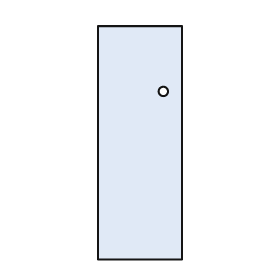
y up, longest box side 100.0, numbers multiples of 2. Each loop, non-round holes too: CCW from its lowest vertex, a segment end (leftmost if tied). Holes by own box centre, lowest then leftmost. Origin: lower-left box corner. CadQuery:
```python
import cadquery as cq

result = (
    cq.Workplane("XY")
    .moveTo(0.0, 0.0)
    .lineTo(36.0, 0.0)
    .lineTo(36.0, 100.0)
    .lineTo(0.0, 100.0)
    .close()
    .moveTo(28.0, 72.0)
    .circle(2.0)
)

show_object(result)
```